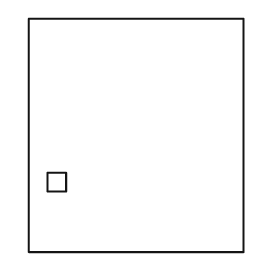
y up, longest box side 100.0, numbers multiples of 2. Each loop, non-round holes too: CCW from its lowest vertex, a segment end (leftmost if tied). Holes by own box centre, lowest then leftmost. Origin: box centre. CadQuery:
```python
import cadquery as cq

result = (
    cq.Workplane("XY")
    .moveTo(-46.0, -50.0)
    .lineTo(46.0, -50.0)
    .lineTo(46.0, 50.0)
    .lineTo(-46.0, 50.0)
    .close()
    .moveTo(-38.0, -24.0)
    .lineTo(-30.0, -24.0)
    .lineTo(-30.0, -16.0)
    .lineTo(-38.0, -16.0)
    .close()
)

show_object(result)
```